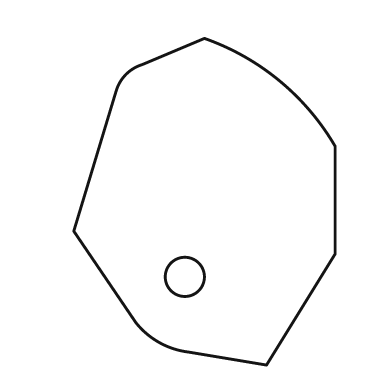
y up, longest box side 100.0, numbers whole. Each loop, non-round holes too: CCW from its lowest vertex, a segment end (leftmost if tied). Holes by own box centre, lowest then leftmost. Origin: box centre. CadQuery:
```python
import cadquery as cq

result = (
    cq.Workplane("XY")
    .moveTo(19.0, -50.0)
    .lineTo(40.0, -16.0)
    .lineTo(40.0, 17.0)
    .threePointArc((23.0, 37.0), (0.0, 50.0))
    .lineTo(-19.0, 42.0)
    .threePointArc((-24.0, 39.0), (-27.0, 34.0))
    .lineTo(-40.0, -9.0)
    .lineTo(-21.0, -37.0)
    .threePointArc((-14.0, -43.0), (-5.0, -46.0))
    .close()
    .moveTo(-6.0, -23.0)
    .circle(6.0)
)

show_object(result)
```